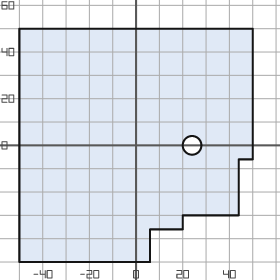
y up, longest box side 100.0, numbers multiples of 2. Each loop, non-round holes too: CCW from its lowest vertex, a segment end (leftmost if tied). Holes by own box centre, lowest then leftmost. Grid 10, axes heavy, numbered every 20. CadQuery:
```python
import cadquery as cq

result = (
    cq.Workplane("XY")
    .moveTo(-50.0, -50.0)
    .lineTo(6.0, -50.0)
    .lineTo(6.0, -36.0)
    .lineTo(20.0, -36.0)
    .lineTo(20.0, -30.0)
    .lineTo(44.0, -30.0)
    .lineTo(44.0, -6.0)
    .lineTo(50.0, -6.0)
    .lineTo(50.0, 50.0)
    .lineTo(-50.0, 50.0)
    .close()
    .moveTo(24.0, 0.0)
    .circle(4.0)
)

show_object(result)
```